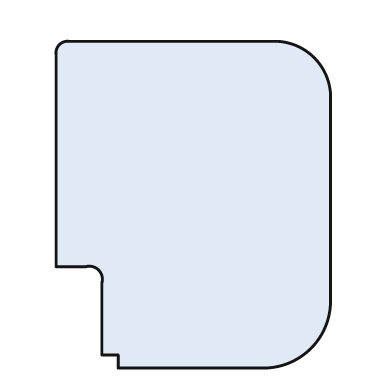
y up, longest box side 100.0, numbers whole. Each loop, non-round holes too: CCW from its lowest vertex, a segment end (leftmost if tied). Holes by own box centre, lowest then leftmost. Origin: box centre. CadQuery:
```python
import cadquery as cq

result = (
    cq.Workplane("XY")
    .moveTo(-23.0, -50.0)
    .lineTo(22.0, -50.0)
    .threePointArc((36.0, -44.0), (42.0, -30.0))
    .lineTo(42.0, 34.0)
    .threePointArc((37.0, 45.0), (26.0, 50.0))
    .lineTo(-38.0, 50.0)
    .threePointArc((-41.0, 49.0), (-42.0, 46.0))
    .lineTo(-42.0, -19.0)
    .lineTo(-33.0, -19.0)
    .threePointArc((-29.0, -20.0), (-28.0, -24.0))
    .lineTo(-28.0, -46.0)
    .lineTo(-23.0, -46.0)
    .close()
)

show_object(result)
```